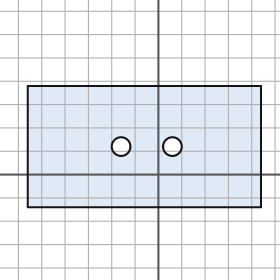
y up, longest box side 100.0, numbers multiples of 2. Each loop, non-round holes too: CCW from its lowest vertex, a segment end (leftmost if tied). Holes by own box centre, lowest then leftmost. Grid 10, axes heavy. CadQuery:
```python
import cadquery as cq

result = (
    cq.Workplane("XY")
    .moveTo(-56.0, -14.0)
    .lineTo(44.0, -14.0)
    .lineTo(44.0, 38.0)
    .lineTo(-56.0, 38.0)
    .close()
    .moveTo(-16.0, 12.0)
    .circle(4.0)
    .moveTo(6.0, 12.0)
    .circle(4.0)
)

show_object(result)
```